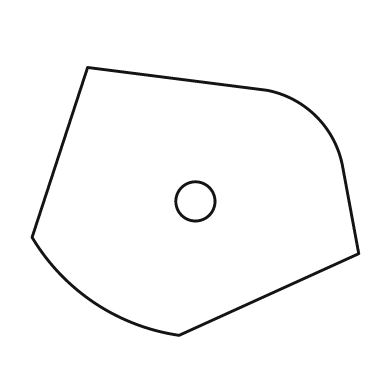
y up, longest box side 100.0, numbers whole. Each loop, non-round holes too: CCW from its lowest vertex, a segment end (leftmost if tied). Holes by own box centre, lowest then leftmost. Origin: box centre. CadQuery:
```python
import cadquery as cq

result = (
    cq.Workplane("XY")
    .moveTo(-5.0, -41.0)
    .lineTo(50.0, -16.0)
    .lineTo(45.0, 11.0)
    .threePointArc((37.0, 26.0), (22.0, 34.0))
    .lineTo(-33.0, 41.0)
    .lineTo(-50.0, -11.0)
    .threePointArc((-31.0, -31.0), (-5.0, -41.0))
    .close()
    .moveTo(0.0, 0.0)
    .circle(6.0)
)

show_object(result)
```